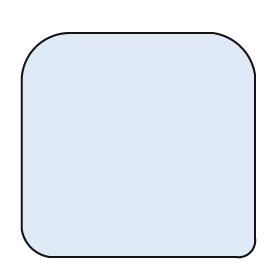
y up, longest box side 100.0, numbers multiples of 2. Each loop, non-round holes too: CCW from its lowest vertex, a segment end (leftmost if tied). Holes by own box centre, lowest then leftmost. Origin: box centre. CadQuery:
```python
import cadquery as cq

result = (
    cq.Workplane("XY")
    .moveTo(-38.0, -48.0)
    .lineTo(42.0, -48.0)
    .threePointArc((48.0, -46.0), (50.0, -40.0))
    .lineTo(50.0, 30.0)
    .threePointArc((44.0, 42.0), (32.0, 48.0))
    .lineTo(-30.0, 48.0)
    .threePointArc((-44.0, 42.0), (-50.0, 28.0))
    .lineTo(-50.0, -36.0)
    .threePointArc((-46.0, -44.0), (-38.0, -48.0))
    .close()
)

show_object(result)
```